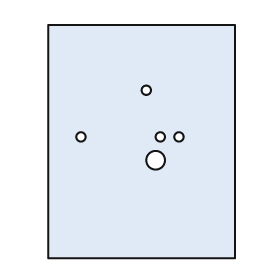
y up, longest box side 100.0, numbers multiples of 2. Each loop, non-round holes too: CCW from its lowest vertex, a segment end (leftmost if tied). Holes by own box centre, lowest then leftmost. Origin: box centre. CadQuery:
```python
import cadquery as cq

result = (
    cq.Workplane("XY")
    .moveTo(-40.0, -50.0)
    .lineTo(40.0, -50.0)
    .lineTo(40.0, 50.0)
    .lineTo(-40.0, 50.0)
    .close()
    .moveTo(6.0, -8.0)
    .circle(4.0)
    .moveTo(-26.0, 2.0)
    .circle(2.0)
    .moveTo(8.0, 2.0)
    .circle(2.0)
    .moveTo(16.0, 2.0)
    .circle(2.0)
    .moveTo(2.0, 22.0)
    .circle(2.0)
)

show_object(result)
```